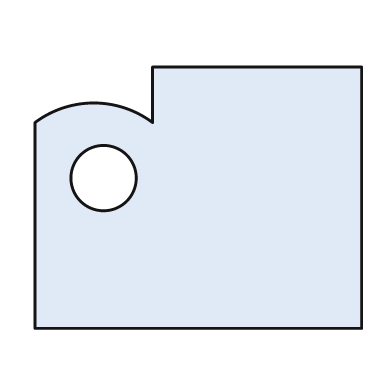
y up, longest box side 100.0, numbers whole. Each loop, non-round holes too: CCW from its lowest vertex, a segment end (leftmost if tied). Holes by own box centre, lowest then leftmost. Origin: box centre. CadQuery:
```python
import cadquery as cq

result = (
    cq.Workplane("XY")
    .moveTo(-50.0, -40.0)
    .lineTo(50.0, -40.0)
    .lineTo(50.0, 40.0)
    .lineTo(-14.0, 40.0)
    .lineTo(-14.0, 23.0)
    .threePointArc((-32.0, 29.0), (-50.0, 23.0))
    .close()
    .moveTo(-29.0, 6.0)
    .circle(10.0)
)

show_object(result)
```